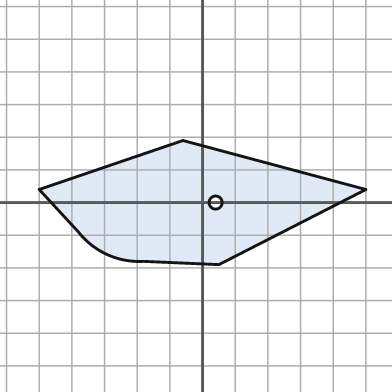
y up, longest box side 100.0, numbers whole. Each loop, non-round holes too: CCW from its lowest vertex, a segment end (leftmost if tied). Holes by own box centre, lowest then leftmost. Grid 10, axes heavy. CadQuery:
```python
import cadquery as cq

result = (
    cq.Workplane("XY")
    .moveTo(5.0, -19.0)
    .lineTo(50.0, 4.0)
    .lineTo(-6.0, 19.0)
    .lineTo(-50.0, 4.0)
    .lineTo(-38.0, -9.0)
    .threePointArc((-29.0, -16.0), (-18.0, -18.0))
    .close()
    .moveTo(4.0, 0.0)
    .circle(2.0)
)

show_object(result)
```